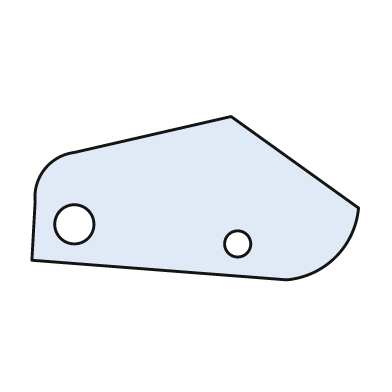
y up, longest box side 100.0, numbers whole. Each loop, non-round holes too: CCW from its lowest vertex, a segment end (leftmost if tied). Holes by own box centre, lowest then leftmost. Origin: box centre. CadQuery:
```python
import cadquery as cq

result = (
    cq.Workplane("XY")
    .moveTo(28.0, -25.0)
    .threePointArc((43.0, -18.0), (50.0, -3.0))
    .lineTo(11.0, 25.0)
    .lineTo(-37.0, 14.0)
    .threePointArc((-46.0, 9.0), (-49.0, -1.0))
    .lineTo(-50.0, -19.0)
    .close()
    .moveTo(13.0, -14.0)
    .circle(4.0)
    .moveTo(-37.0, -8.0)
    .circle(6.0)
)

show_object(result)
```